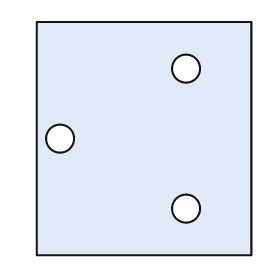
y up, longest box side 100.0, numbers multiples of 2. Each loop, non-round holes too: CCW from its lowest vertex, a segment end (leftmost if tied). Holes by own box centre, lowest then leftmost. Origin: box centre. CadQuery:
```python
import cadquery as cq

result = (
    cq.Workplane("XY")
    .moveTo(-46.0, -50.0)
    .lineTo(46.0, -50.0)
    .lineTo(46.0, 50.0)
    .lineTo(-46.0, 50.0)
    .close()
    .moveTo(18.0, -30.0)
    .circle(6.0)
    .moveTo(-36.0, 0.0)
    .circle(6.0)
    .moveTo(18.0, 30.0)
    .circle(6.0)
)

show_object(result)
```